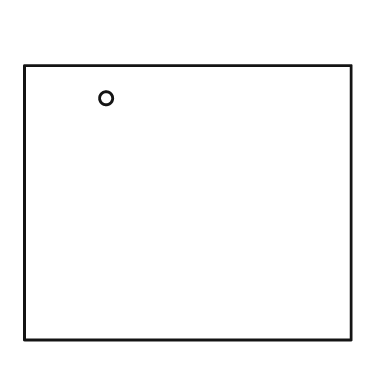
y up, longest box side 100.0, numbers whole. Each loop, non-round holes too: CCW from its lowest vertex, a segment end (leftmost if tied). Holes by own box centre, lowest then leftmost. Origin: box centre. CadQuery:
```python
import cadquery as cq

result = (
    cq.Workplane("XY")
    .moveTo(-50.0, -42.0)
    .lineTo(50.0, -42.0)
    .lineTo(50.0, 42.0)
    .lineTo(-50.0, 42.0)
    .close()
    .moveTo(-25.0, 32.0)
    .circle(2.0)
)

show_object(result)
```